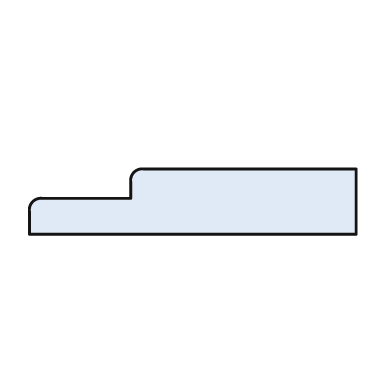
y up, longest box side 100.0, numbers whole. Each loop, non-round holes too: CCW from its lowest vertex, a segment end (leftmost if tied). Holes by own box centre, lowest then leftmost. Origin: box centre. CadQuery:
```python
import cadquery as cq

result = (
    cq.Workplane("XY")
    .moveTo(-50.0, -10.0)
    .lineTo(50.0, -10.0)
    .lineTo(50.0, 10.0)
    .lineTo(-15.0, 10.0)
    .threePointArc((-18.0, 9.0), (-19.0, 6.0))
    .lineTo(-19.0, 1.0)
    .lineTo(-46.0, 1.0)
    .threePointArc((-49.0, 0.0), (-50.0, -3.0))
    .close()
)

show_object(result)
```